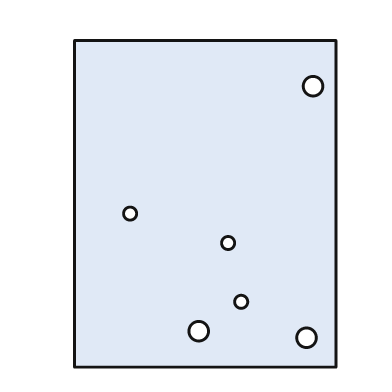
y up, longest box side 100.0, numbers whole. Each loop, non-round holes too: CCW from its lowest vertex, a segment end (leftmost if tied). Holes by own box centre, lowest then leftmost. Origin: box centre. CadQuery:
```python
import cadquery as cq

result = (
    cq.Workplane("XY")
    .moveTo(-40.0, -50.0)
    .lineTo(40.0, -50.0)
    .lineTo(40.0, 50.0)
    .lineTo(-40.0, 50.0)
    .close()
    .moveTo(31.0, -41.0)
    .circle(3.0)
    .moveTo(-2.0, -39.0)
    .circle(3.0)
    .moveTo(11.0, -30.0)
    .circle(2.0)
    .moveTo(7.0, -12.0)
    .circle(2.0)
    .moveTo(-23.0, -3.0)
    .circle(2.0)
    .moveTo(33.0, 36.0)
    .circle(3.0)
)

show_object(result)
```